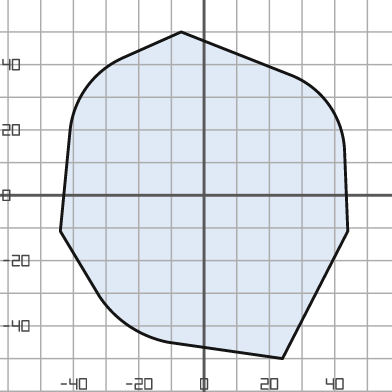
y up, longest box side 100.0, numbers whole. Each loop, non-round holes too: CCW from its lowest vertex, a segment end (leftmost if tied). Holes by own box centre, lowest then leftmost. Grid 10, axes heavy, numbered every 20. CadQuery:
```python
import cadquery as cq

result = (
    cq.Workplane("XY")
    .moveTo(24.0, -50.0)
    .lineTo(44.0, -11.0)
    .lineTo(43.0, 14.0)
    .threePointArc((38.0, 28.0), (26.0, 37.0))
    .lineTo(-7.0, 50.0)
    .lineTo(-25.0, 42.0)
    .threePointArc((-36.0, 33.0), (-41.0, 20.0))
    .lineTo(-44.0, -11.0)
    .lineTo(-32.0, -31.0)
    .threePointArc((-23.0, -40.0), (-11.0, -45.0))
    .close()
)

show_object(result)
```